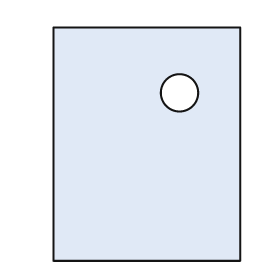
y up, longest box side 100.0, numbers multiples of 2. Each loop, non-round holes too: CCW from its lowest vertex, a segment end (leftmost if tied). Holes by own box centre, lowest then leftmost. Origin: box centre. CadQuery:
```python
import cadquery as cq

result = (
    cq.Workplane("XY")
    .moveTo(-40.0, -50.0)
    .lineTo(40.0, -50.0)
    .lineTo(40.0, 50.0)
    .lineTo(-40.0, 50.0)
    .close()
    .moveTo(14.0, 22.0)
    .circle(8.0)
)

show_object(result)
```